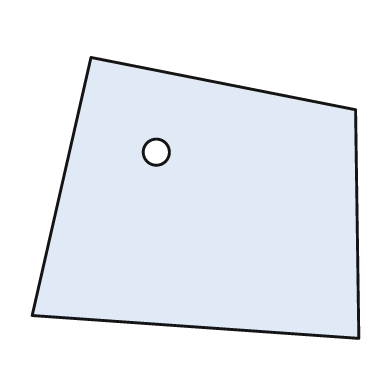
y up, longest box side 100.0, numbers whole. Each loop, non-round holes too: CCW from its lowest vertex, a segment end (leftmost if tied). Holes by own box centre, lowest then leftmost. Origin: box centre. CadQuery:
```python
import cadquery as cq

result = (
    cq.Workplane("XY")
    .moveTo(50.0, -43.0)
    .lineTo(49.0, 27.0)
    .lineTo(-32.0, 43.0)
    .lineTo(-50.0, -36.0)
    .close()
    .moveTo(-12.0, 14.0)
    .circle(4.0)
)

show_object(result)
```